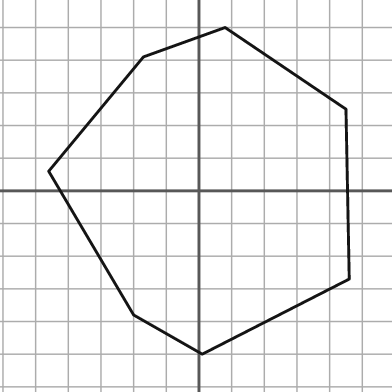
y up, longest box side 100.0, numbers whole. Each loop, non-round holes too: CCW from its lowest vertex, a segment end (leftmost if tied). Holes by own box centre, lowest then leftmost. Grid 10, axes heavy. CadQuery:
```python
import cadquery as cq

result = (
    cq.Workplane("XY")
    .moveTo(1.0, -50.0)
    .lineTo(46.0, -27.0)
    .lineTo(45.0, 25.0)
    .lineTo(8.0, 50.0)
    .lineTo(-17.0, 41.0)
    .lineTo(-46.0, 6.0)
    .lineTo(-20.0, -38.0)
    .close()
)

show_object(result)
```